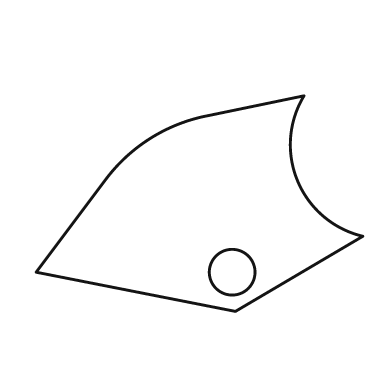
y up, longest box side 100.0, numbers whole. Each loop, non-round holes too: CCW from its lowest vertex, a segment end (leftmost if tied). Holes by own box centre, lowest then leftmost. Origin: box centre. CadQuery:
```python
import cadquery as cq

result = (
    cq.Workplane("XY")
    .moveTo(11.0, -33.0)
    .lineTo(50.0, -10.0)
    .threePointArc((30.0, 7.0), (32.0, 33.0))
    .lineTo(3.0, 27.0)
    .threePointArc((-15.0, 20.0), (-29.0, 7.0))
    .lineTo(-50.0, -21.0)
    .close()
    .moveTo(10.0, -21.0)
    .circle(7.0)
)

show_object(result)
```